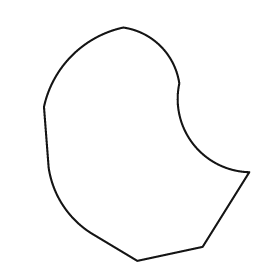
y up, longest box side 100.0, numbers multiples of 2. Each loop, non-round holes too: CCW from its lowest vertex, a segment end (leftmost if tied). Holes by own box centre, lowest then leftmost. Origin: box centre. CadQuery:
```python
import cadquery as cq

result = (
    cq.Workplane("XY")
    .moveTo(-4.0, -50.0)
    .lineTo(24.0, -44.0)
    .lineTo(44.0, -12.0)
    .threePointArc((20.0, 0.0), (14.0, 26.0))
    .threePointArc((6.0, 42.0), (-10.0, 50.0))
    .threePointArc((-32.0, 38.0), (-44.0, 16.0))
    .lineTo(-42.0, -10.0)
    .threePointArc((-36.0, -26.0), (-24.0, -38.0))
    .close()
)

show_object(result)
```